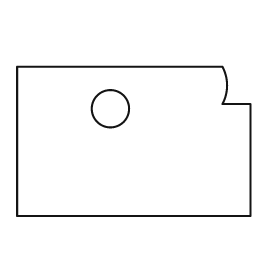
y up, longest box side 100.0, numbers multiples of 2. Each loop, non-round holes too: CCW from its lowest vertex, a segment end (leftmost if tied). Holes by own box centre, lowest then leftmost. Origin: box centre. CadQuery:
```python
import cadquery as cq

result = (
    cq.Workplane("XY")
    .moveTo(-50.0, -32.0)
    .lineTo(50.0, -32.0)
    .lineTo(50.0, 16.0)
    .lineTo(38.0, 16.0)
    .threePointArc((40.0, 24.0), (38.0, 32.0))
    .lineTo(-50.0, 32.0)
    .close()
    .moveTo(-10.0, 14.0)
    .circle(8.0)
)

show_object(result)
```